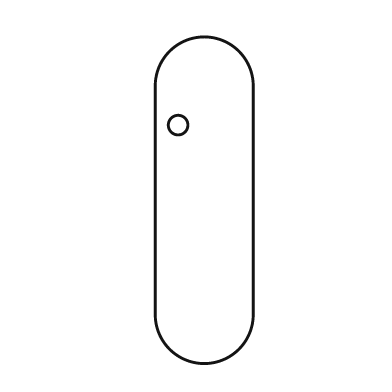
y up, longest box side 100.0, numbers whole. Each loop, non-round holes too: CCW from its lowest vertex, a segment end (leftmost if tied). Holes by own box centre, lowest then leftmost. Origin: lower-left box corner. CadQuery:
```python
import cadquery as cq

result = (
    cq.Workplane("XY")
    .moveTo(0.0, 15.0)
    .threePointArc((15.0, 0.0), (30.0, 15.0))
    .lineTo(30.0, 85.0)
    .threePointArc((15.0, 100.0), (0.0, 85.0))
    .close()
    .moveTo(7.0, 73.0)
    .circle(3.0)
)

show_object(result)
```